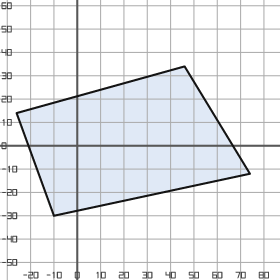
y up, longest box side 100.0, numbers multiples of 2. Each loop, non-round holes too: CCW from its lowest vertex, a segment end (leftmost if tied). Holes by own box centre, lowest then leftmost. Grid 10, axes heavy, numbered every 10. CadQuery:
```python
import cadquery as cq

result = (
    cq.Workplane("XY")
    .moveTo(-10.0, -30.0)
    .lineTo(74.0, -12.0)
    .lineTo(46.0, 34.0)
    .lineTo(-26.0, 14.0)
    .close()
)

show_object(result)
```